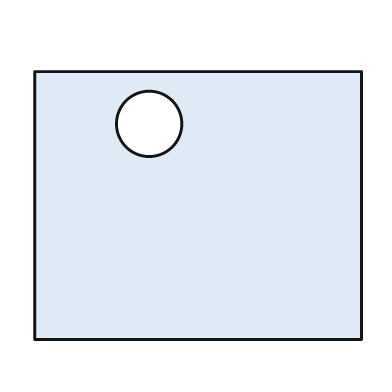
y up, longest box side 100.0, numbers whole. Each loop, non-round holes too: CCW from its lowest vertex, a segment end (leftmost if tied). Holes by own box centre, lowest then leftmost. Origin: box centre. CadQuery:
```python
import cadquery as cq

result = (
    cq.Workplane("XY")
    .moveTo(-50.0, -41.0)
    .lineTo(50.0, -41.0)
    .lineTo(50.0, 41.0)
    .lineTo(-50.0, 41.0)
    .close()
    .moveTo(-15.0, 25.0)
    .circle(10.0)
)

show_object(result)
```